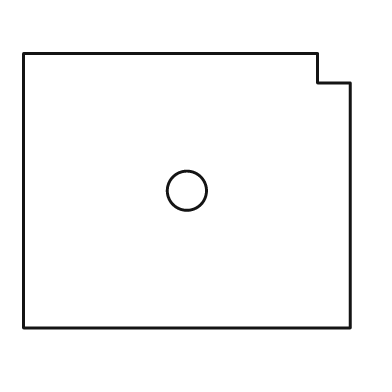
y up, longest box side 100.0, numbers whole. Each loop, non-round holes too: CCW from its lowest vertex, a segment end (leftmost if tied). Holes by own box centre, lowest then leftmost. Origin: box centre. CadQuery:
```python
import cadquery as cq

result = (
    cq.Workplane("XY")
    .moveTo(-50.0, -42.0)
    .lineTo(50.0, -42.0)
    .lineTo(50.0, 33.0)
    .lineTo(40.0, 33.0)
    .lineTo(40.0, 42.0)
    .lineTo(-50.0, 42.0)
    .close()
    .moveTo(0.0, 0.0)
    .circle(6.0)
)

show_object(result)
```